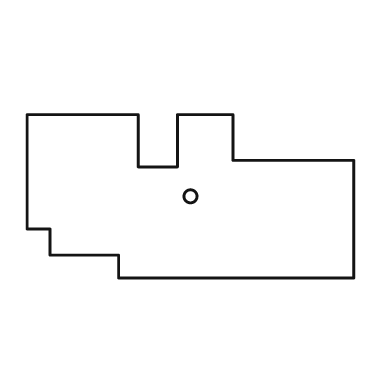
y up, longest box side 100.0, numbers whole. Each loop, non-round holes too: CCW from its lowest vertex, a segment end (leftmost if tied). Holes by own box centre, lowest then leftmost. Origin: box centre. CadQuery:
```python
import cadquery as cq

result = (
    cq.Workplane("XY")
    .moveTo(-22.0, -25.0)
    .lineTo(50.0, -25.0)
    .lineTo(50.0, 11.0)
    .lineTo(13.0, 11.0)
    .lineTo(13.0, 25.0)
    .lineTo(-4.0, 25.0)
    .lineTo(-4.0, 9.0)
    .lineTo(-16.0, 9.0)
    .lineTo(-16.0, 25.0)
    .lineTo(-50.0, 25.0)
    .lineTo(-50.0, -10.0)
    .lineTo(-43.0, -10.0)
    .lineTo(-43.0, -18.0)
    .lineTo(-22.0, -18.0)
    .close()
    .moveTo(0.0, 0.0)
    .circle(2.0)
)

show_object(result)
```